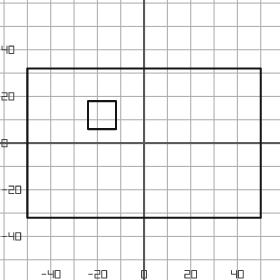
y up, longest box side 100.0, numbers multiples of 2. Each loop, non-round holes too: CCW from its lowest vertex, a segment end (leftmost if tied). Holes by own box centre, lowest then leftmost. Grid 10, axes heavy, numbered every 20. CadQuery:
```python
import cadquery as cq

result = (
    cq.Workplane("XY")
    .moveTo(-50.0, -32.0)
    .lineTo(50.0, -32.0)
    .lineTo(50.0, 32.0)
    .lineTo(-50.0, 32.0)
    .close()
    .moveTo(-24.0, 6.0)
    .lineTo(-12.0, 6.0)
    .lineTo(-12.0, 18.0)
    .lineTo(-24.0, 18.0)
    .close()
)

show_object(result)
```